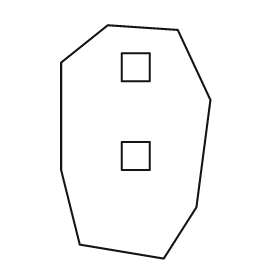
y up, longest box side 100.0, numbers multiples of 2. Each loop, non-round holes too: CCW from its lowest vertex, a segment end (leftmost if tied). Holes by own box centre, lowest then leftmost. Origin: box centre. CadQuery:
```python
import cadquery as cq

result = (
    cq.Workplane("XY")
    .moveTo(12.0, -50.0)
    .lineTo(26.0, -28.0)
    .lineTo(32.0, 18.0)
    .lineTo(18.0, 48.0)
    .lineTo(-12.0, 50.0)
    .lineTo(-32.0, 34.0)
    .lineTo(-32.0, -12.0)
    .lineTo(-24.0, -44.0)
    .close()
    .moveTo(-6.0, -12.0)
    .lineTo(6.0, -12.0)
    .lineTo(6.0, 0.0)
    .lineTo(-6.0, 0.0)
    .close()
    .moveTo(-6.0, 26.0)
    .lineTo(6.0, 26.0)
    .lineTo(6.0, 38.0)
    .lineTo(-6.0, 38.0)
    .close()
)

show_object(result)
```